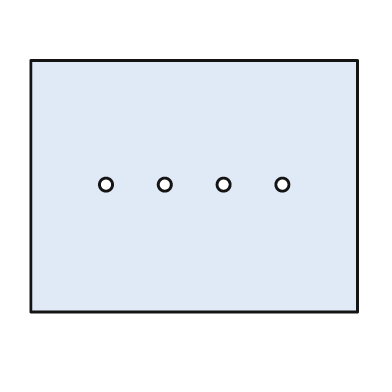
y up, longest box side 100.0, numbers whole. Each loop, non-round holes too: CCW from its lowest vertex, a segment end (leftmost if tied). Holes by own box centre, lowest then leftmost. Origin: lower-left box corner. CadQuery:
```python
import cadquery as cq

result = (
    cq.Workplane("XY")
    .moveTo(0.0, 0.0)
    .lineTo(100.0, 0.0)
    .lineTo(100.0, 77.0)
    .lineTo(0.0, 77.0)
    .close()
    .moveTo(23.0, 39.0)
    .circle(2.0)
    .moveTo(41.0, 39.0)
    .circle(2.0)
    .moveTo(59.0, 39.0)
    .circle(2.0)
    .moveTo(77.0, 39.0)
    .circle(2.0)
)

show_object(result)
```